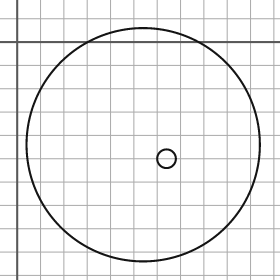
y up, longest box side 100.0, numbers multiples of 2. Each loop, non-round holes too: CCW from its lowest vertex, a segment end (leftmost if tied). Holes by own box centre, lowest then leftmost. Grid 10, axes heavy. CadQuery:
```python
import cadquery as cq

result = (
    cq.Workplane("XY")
    .moveTo(54.0, -44.0)
    .circle(50.0)
    .moveTo(64.0, -50.0)
    .circle(4.0)
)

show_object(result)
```